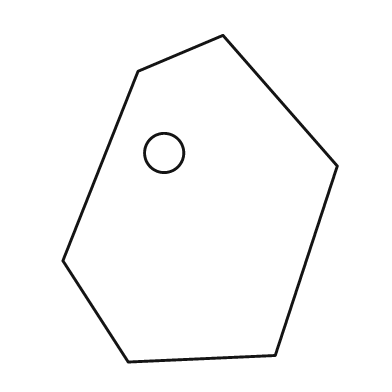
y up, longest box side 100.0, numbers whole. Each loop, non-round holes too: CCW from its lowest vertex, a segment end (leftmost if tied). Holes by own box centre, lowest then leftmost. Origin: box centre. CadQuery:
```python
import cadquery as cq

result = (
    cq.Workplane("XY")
    .moveTo(-22.0, -50.0)
    .lineTo(23.0, -48.0)
    .lineTo(42.0, 10.0)
    .lineTo(7.0, 50.0)
    .lineTo(-19.0, 39.0)
    .lineTo(-42.0, -19.0)
    .close()
    .moveTo(-11.0, 14.0)
    .circle(6.0)
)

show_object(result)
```